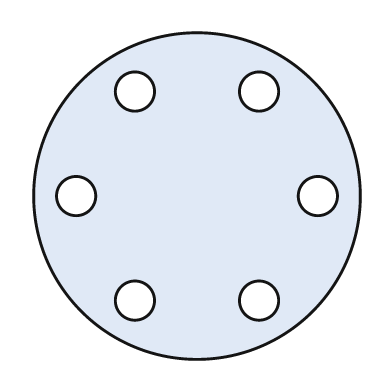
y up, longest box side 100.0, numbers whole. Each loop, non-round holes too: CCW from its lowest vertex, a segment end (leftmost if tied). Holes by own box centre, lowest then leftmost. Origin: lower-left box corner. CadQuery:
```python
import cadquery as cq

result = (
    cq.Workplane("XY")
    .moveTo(50.0, 50.0)
    .circle(50.0)
    .moveTo(31.0, 18.0)
    .circle(6.0)
    .moveTo(69.0, 18.0)
    .circle(6.0)
    .moveTo(13.0, 50.0)
    .circle(6.0)
    .moveTo(87.0, 50.0)
    .circle(6.0)
    .moveTo(31.0, 82.0)
    .circle(6.0)
    .moveTo(69.0, 82.0)
    .circle(6.0)
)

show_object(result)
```